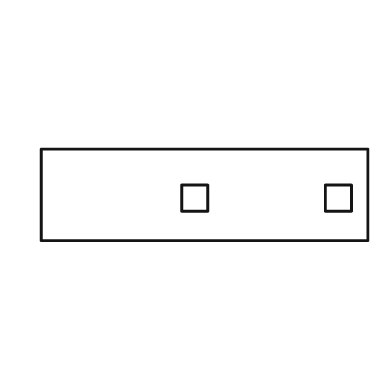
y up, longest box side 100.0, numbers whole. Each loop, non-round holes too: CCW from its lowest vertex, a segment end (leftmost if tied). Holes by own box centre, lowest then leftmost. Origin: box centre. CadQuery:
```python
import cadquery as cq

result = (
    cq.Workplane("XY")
    .moveTo(-50.0, -14.0)
    .lineTo(50.0, -14.0)
    .lineTo(50.0, 14.0)
    .lineTo(-50.0, 14.0)
    .close()
    .moveTo(-7.0, -5.0)
    .lineTo(1.0, -5.0)
    .lineTo(1.0, 3.0)
    .lineTo(-7.0, 3.0)
    .close()
    .moveTo(37.0, -5.0)
    .lineTo(45.0, -5.0)
    .lineTo(45.0, 3.0)
    .lineTo(37.0, 3.0)
    .close()
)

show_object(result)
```